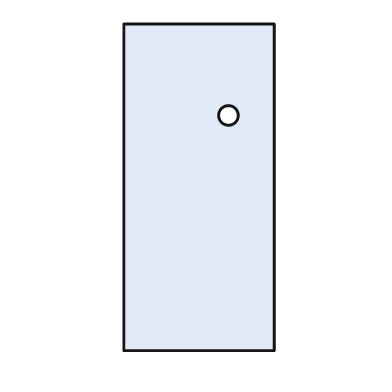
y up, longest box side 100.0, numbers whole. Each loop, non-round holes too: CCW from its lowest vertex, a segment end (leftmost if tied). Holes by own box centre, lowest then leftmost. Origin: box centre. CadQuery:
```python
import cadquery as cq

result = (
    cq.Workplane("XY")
    .moveTo(-23.0, -50.0)
    .lineTo(23.0, -50.0)
    .lineTo(23.0, 50.0)
    .lineTo(-23.0, 50.0)
    .close()
    .moveTo(9.0, 22.0)
    .circle(3.0)
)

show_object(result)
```